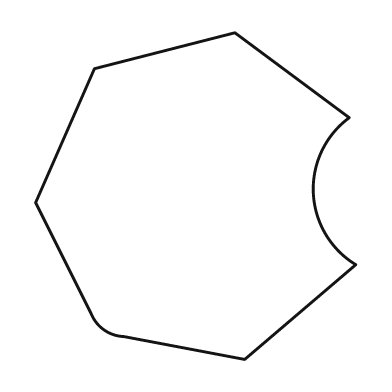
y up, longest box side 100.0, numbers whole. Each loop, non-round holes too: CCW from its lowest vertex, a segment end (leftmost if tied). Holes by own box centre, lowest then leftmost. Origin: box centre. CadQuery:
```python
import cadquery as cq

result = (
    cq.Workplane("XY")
    .moveTo(15.0, -50.0)
    .lineTo(49.0, -21.0)
    .threePointArc((36.0, 1.0), (47.0, 24.0))
    .lineTo(12.0, 50.0)
    .lineTo(-31.0, 39.0)
    .lineTo(-49.0, -2.0)
    .lineTo(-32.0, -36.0)
    .threePointArc((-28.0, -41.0), (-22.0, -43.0))
    .close()
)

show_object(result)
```